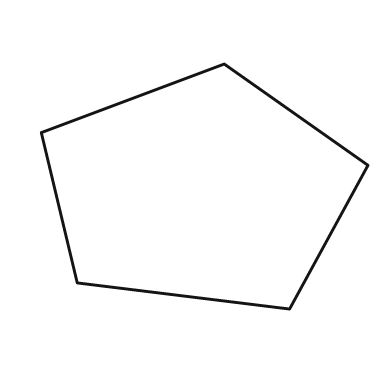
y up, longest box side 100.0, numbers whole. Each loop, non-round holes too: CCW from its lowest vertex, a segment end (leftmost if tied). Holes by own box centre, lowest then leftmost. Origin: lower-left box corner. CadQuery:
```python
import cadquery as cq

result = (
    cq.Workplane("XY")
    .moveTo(76.0, 0.0)
    .lineTo(100.0, 44.0)
    .lineTo(56.0, 75.0)
    .lineTo(0.0, 54.0)
    .lineTo(11.0, 8.0)
    .close()
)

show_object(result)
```